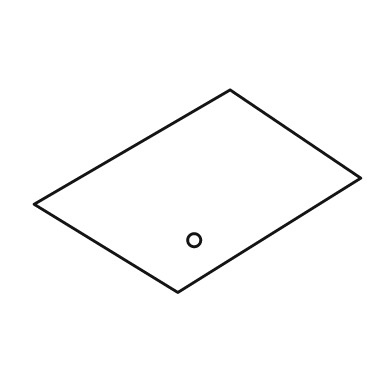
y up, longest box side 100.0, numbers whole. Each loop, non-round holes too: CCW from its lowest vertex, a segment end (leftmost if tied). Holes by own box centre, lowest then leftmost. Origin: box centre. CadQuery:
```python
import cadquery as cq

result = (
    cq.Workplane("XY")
    .moveTo(-6.0, -31.0)
    .lineTo(50.0, 4.0)
    .lineTo(10.0, 31.0)
    .lineTo(-50.0, -4.0)
    .close()
    .moveTo(-1.0, -15.0)
    .circle(2.0)
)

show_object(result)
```